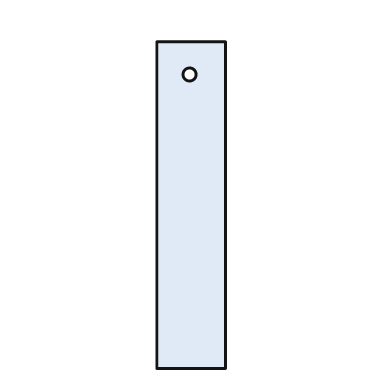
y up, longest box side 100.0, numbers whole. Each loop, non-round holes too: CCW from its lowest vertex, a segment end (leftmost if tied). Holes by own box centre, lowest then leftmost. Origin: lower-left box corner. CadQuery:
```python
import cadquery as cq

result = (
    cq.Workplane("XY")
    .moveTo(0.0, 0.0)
    .lineTo(21.0, 0.0)
    .lineTo(21.0, 100.0)
    .lineTo(0.0, 100.0)
    .close()
    .moveTo(10.0, 90.0)
    .circle(2.0)
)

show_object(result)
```